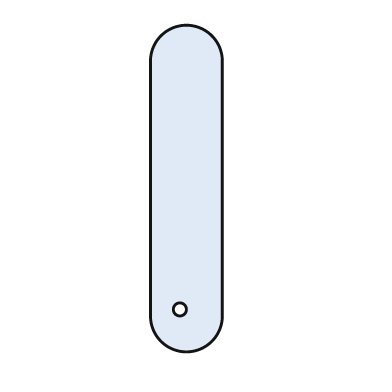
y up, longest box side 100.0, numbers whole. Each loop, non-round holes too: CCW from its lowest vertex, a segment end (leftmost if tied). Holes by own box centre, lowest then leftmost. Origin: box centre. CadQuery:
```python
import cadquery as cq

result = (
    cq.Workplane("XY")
    .moveTo(-11.0, -39.0)
    .threePointArc((0.0, -50.0), (11.0, -39.0))
    .lineTo(11.0, 39.0)
    .threePointArc((0.0, 50.0), (-11.0, 39.0))
    .close()
    .moveTo(-2.0, -37.0)
    .circle(2.0)
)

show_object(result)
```